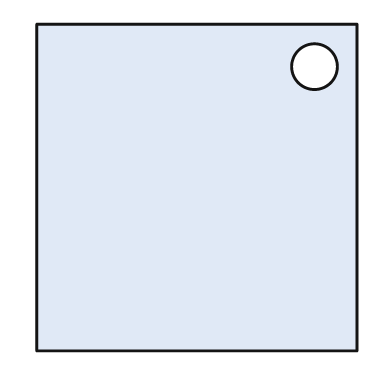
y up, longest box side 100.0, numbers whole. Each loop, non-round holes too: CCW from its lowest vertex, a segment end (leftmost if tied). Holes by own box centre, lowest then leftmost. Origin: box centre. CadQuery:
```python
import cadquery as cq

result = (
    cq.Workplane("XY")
    .moveTo(-49.0, -50.0)
    .lineTo(49.0, -50.0)
    .lineTo(49.0, 50.0)
    .lineTo(-49.0, 50.0)
    .close()
    .moveTo(36.0, 37.0)
    .circle(7.0)
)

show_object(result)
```